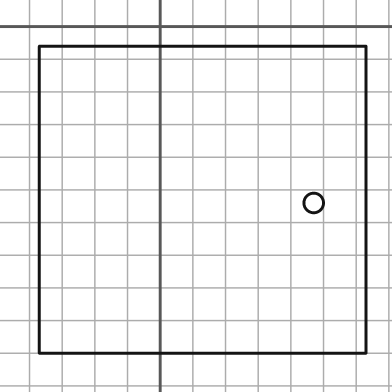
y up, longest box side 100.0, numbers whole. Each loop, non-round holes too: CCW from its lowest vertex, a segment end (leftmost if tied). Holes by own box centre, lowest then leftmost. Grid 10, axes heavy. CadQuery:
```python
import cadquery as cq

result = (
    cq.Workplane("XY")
    .moveTo(-37.0, -100.0)
    .lineTo(63.0, -100.0)
    .lineTo(63.0, -6.0)
    .lineTo(-37.0, -6.0)
    .close()
    .moveTo(47.0, -54.0)
    .circle(3.0)
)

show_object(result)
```